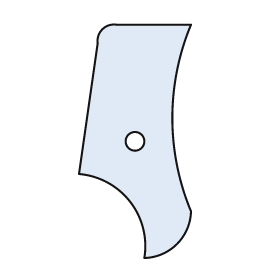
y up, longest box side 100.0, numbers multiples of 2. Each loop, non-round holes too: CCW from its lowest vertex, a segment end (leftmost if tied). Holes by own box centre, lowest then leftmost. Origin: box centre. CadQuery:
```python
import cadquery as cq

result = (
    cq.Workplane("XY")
    .moveTo(4.0, -50.0)
    .threePointArc((18.0, -44.0), (24.0, -30.0))
    .threePointArc((16.0, 10.0), (24.0, 50.0))
    .lineTo(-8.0, 50.0)
    .threePointArc((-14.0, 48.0), (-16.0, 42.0))
    .lineTo(-24.0, -14.0)
    .threePointArc((-2.0, -26.0), (4.0, -50.0))
    .close()
    .moveTo(0.0, 0.0)
    .circle(4.0)
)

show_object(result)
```